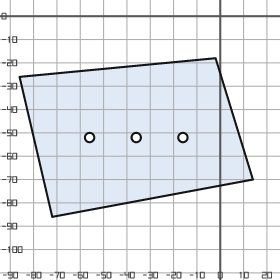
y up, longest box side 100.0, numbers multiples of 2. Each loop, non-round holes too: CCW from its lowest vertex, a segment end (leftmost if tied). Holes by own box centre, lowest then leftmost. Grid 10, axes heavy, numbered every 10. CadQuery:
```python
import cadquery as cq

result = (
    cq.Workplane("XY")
    .moveTo(-72.0, -86.0)
    .lineTo(14.0, -70.0)
    .lineTo(-2.0, -18.0)
    .lineTo(-86.0, -26.0)
    .close()
    .moveTo(-56.0, -52.0)
    .circle(2.0)
    .moveTo(-36.0, -52.0)
    .circle(2.0)
    .moveTo(-16.0, -52.0)
    .circle(2.0)
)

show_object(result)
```